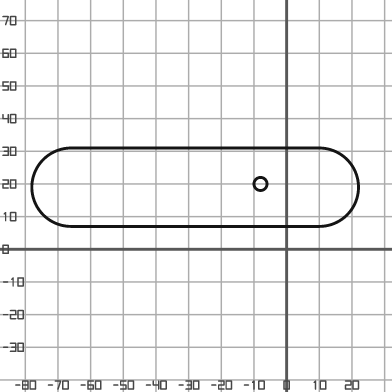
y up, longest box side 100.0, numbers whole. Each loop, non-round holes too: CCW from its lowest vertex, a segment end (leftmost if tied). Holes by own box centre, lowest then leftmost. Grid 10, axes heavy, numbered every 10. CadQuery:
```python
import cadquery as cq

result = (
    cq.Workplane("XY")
    .moveTo(-66.0, 7.0)
    .lineTo(10.0, 7.0)
    .threePointArc((22.0, 19.0), (10.0, 31.0))
    .lineTo(-66.0, 31.0)
    .threePointArc((-78.0, 19.0), (-66.0, 7.0))
    .close()
    .moveTo(-8.0, 20.0)
    .circle(2.0)
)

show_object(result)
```